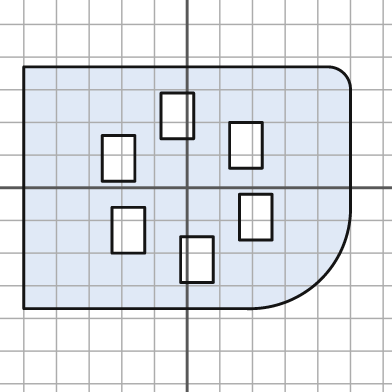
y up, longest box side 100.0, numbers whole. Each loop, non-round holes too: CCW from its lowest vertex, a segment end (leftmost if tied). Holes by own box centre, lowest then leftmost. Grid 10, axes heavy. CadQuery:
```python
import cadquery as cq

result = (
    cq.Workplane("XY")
    .moveTo(-50.0, -37.0)
    .lineTo(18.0, -37.0)
    .threePointArc((41.0, -28.0), (50.0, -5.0))
    .lineTo(50.0, 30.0)
    .threePointArc((48.0, 35.0), (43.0, 37.0))
    .lineTo(-50.0, 37.0)
    .close()
    .moveTo(-2.0, -29.0)
    .lineTo(8.0, -29.0)
    .lineTo(8.0, -15.0)
    .lineTo(-2.0, -15.0)
    .close()
    .moveTo(-23.0, -20.0)
    .lineTo(-13.0, -20.0)
    .lineTo(-13.0, -6.0)
    .lineTo(-23.0, -6.0)
    .close()
    .moveTo(16.0, -16.0)
    .lineTo(26.0, -16.0)
    .lineTo(26.0, -2.0)
    .lineTo(16.0, -2.0)
    .close()
    .moveTo(-26.0, 2.0)
    .lineTo(-16.0, 2.0)
    .lineTo(-16.0, 16.0)
    .lineTo(-26.0, 16.0)
    .close()
    .moveTo(13.0, 6.0)
    .lineTo(23.0, 6.0)
    .lineTo(23.0, 20.0)
    .lineTo(13.0, 20.0)
    .close()
    .moveTo(-8.0, 15.0)
    .lineTo(2.0, 15.0)
    .lineTo(2.0, 29.0)
    .lineTo(-8.0, 29.0)
    .close()
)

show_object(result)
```